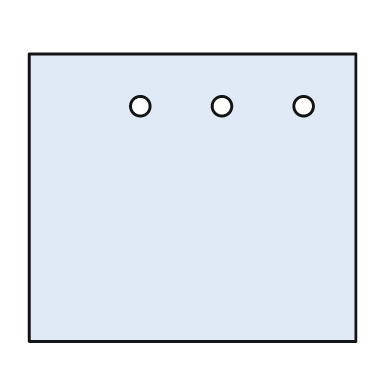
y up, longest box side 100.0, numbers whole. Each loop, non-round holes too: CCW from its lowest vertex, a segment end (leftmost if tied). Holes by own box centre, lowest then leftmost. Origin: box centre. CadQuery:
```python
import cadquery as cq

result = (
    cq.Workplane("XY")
    .moveTo(-50.0, -44.0)
    .lineTo(50.0, -44.0)
    .lineTo(50.0, 44.0)
    .lineTo(-50.0, 44.0)
    .close()
    .moveTo(-16.0, 28.0)
    .circle(3.0)
    .moveTo(9.0, 28.0)
    .circle(3.0)
    .moveTo(34.0, 28.0)
    .circle(3.0)
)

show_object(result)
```